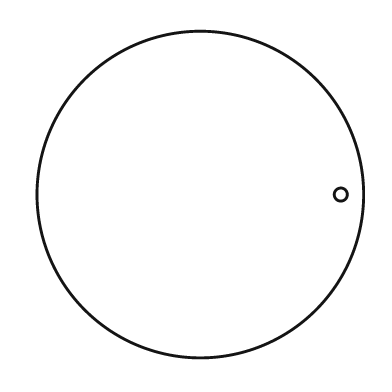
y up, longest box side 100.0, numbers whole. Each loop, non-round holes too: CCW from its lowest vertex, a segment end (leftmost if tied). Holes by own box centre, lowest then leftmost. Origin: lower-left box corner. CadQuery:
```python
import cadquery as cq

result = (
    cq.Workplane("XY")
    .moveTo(50.0, 50.0)
    .circle(50.0)
    .moveTo(93.0, 50.0)
    .circle(2.0)
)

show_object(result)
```